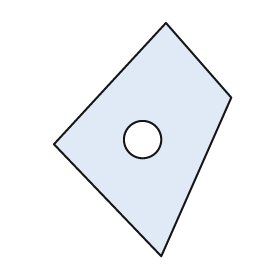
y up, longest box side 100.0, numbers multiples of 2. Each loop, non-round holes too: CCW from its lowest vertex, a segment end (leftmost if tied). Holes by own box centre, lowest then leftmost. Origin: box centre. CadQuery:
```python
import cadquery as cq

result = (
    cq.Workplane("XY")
    .moveTo(8.0, -50.0)
    .lineTo(38.0, 18.0)
    .lineTo(10.0, 50.0)
    .lineTo(-38.0, -2.0)
    .close()
    .moveTo(0.0, 0.0)
    .circle(8.0)
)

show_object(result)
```